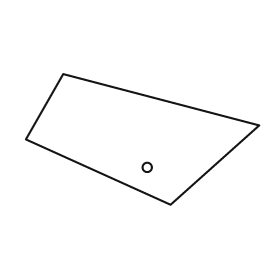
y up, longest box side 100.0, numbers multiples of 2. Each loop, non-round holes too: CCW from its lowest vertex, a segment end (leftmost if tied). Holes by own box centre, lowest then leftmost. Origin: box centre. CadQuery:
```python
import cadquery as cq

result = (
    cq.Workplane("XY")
    .moveTo(12.0, -28.0)
    .lineTo(50.0, 6.0)
    .lineTo(-34.0, 28.0)
    .lineTo(-50.0, 0.0)
    .close()
    .moveTo(2.0, -12.0)
    .circle(2.0)
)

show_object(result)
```